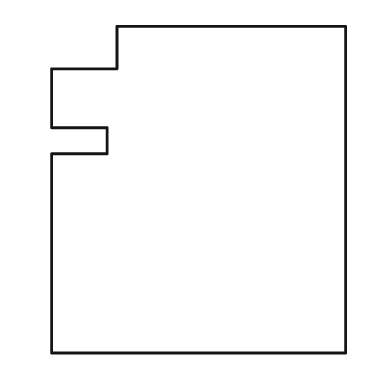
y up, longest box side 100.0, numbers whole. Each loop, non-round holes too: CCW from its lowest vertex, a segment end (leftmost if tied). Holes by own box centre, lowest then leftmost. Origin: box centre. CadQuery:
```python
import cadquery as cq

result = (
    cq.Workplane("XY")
    .moveTo(-45.0, -50.0)
    .lineTo(45.0, -50.0)
    .lineTo(45.0, 50.0)
    .lineTo(-25.0, 50.0)
    .lineTo(-25.0, 37.0)
    .lineTo(-45.0, 37.0)
    .lineTo(-45.0, 19.0)
    .lineTo(-28.0, 19.0)
    .lineTo(-28.0, 11.0)
    .lineTo(-45.0, 11.0)
    .close()
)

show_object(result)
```